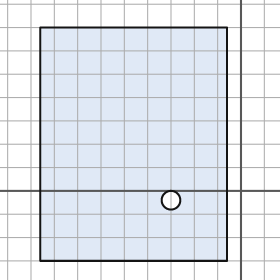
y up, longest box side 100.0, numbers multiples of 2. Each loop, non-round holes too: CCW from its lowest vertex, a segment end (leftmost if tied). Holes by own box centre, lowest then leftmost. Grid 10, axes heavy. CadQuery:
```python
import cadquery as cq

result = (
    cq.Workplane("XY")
    .moveTo(-86.0, -30.0)
    .lineTo(-6.0, -30.0)
    .lineTo(-6.0, 70.0)
    .lineTo(-86.0, 70.0)
    .close()
    .moveTo(-30.0, -4.0)
    .circle(4.0)
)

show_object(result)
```